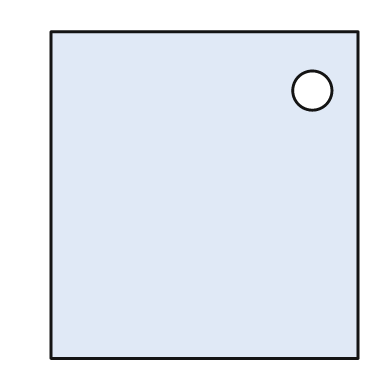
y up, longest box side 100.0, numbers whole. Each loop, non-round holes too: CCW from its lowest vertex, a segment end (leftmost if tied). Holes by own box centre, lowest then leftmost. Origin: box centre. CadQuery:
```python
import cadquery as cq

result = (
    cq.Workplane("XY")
    .moveTo(-47.0, -50.0)
    .lineTo(47.0, -50.0)
    .lineTo(47.0, 50.0)
    .lineTo(-47.0, 50.0)
    .close()
    .moveTo(33.0, 32.0)
    .circle(6.0)
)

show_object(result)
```